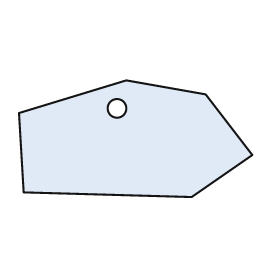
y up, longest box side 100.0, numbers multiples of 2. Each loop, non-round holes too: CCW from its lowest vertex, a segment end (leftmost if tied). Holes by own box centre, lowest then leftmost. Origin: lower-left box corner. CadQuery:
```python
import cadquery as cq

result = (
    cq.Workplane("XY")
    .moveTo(74.0, 0.0)
    .lineTo(100.0, 18.0)
    .lineTo(80.0, 44.0)
    .lineTo(46.0, 50.0)
    .lineTo(0.0, 36.0)
    .lineTo(2.0, 2.0)
    .close()
    .moveTo(42.0, 38.0)
    .circle(4.0)
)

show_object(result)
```